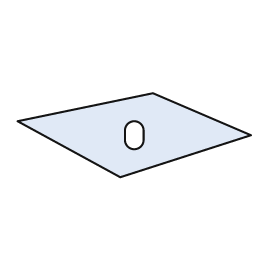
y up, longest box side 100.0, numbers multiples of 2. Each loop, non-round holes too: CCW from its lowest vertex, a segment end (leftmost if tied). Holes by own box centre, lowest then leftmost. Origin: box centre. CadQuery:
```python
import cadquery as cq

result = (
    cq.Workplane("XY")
    .moveTo(-6.0, -18.0)
    .lineTo(50.0, 0.0)
    .lineTo(8.0, 18.0)
    .lineTo(-50.0, 6.0)
    .close()
    .moveTo(-4.0, -2.0)
    .threePointArc((0.0, -6.0), (4.0, -2.0))
    .lineTo(4.0, 2.0)
    .threePointArc((0.0, 6.0), (-4.0, 2.0))
    .close()
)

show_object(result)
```